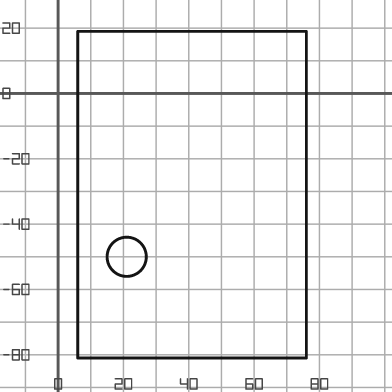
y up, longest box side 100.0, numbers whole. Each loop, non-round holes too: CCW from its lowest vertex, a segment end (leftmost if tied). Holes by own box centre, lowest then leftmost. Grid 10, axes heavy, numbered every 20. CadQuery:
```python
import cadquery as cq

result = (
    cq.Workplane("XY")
    .moveTo(6.0, -81.0)
    .lineTo(76.0, -81.0)
    .lineTo(76.0, 19.0)
    .lineTo(6.0, 19.0)
    .close()
    .moveTo(21.0, -50.0)
    .circle(6.0)
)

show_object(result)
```